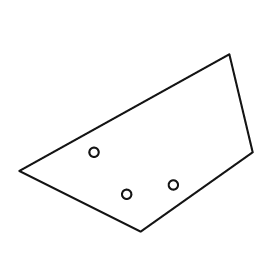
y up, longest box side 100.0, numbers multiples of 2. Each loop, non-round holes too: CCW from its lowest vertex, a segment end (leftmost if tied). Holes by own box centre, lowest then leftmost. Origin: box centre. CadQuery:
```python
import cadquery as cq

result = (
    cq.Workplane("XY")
    .moveTo(2.0, -38.0)
    .lineTo(50.0, -4.0)
    .lineTo(40.0, 38.0)
    .lineTo(-50.0, -12.0)
    .close()
    .moveTo(-4.0, -22.0)
    .circle(2.0)
    .moveTo(16.0, -18.0)
    .circle(2.0)
    .moveTo(-18.0, -4.0)
    .circle(2.0)
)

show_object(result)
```